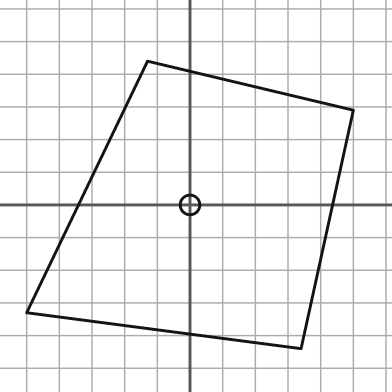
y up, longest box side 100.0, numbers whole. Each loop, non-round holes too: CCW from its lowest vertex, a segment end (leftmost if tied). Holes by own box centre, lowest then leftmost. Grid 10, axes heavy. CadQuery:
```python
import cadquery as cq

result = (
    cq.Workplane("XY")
    .moveTo(34.0, -44.0)
    .lineTo(50.0, 29.0)
    .lineTo(-13.0, 44.0)
    .lineTo(-50.0, -33.0)
    .close()
    .moveTo(0.0, 0.0)
    .circle(3.0)
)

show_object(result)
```